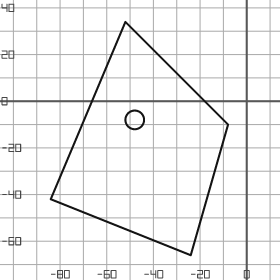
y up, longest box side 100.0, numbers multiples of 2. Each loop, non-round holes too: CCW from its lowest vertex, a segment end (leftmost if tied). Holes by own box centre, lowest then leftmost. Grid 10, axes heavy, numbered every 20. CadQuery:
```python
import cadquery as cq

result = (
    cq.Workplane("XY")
    .moveTo(-24.0, -66.0)
    .lineTo(-8.0, -10.0)
    .lineTo(-52.0, 34.0)
    .lineTo(-84.0, -42.0)
    .close()
    .moveTo(-48.0, -8.0)
    .circle(4.0)
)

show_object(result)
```